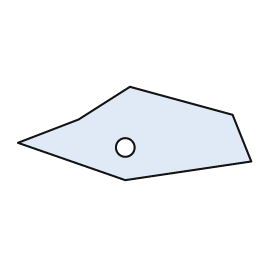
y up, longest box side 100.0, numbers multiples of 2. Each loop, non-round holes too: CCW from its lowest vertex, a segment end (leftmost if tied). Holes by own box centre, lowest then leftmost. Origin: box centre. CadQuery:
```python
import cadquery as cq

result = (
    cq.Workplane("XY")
    .moveTo(-4.0, -20.0)
    .lineTo(50.0, -12.0)
    .lineTo(42.0, 8.0)
    .lineTo(-2.0, 20.0)
    .lineTo(-24.0, 6.0)
    .lineTo(-50.0, -4.0)
    .close()
    .moveTo(-4.0, -6.0)
    .circle(4.0)
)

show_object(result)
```